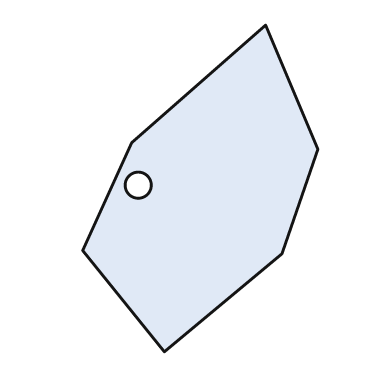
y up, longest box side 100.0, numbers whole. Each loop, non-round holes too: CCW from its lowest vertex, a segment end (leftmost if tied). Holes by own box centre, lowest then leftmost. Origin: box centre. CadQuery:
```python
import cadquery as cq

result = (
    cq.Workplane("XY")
    .moveTo(-11.0, -50.0)
    .lineTo(25.0, -20.0)
    .lineTo(36.0, 12.0)
    .lineTo(20.0, 50.0)
    .lineTo(-21.0, 14.0)
    .lineTo(-36.0, -19.0)
    .close()
    .moveTo(-19.0, 1.0)
    .circle(4.0)
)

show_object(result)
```